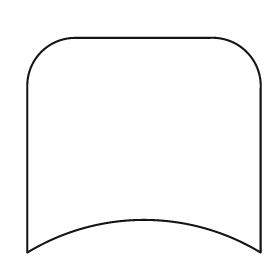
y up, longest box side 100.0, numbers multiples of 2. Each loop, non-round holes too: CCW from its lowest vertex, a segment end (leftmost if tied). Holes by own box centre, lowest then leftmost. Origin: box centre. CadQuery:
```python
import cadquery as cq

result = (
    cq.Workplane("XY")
    .moveTo(-50.0, -46.0)
    .threePointArc((0.0, -32.0), (50.0, -46.0))
    .lineTo(50.0, 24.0)
    .threePointArc((44.0, 40.0), (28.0, 46.0))
    .lineTo(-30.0, 46.0)
    .threePointArc((-44.0, 40.0), (-50.0, 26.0))
    .close()
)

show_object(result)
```